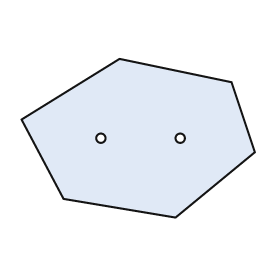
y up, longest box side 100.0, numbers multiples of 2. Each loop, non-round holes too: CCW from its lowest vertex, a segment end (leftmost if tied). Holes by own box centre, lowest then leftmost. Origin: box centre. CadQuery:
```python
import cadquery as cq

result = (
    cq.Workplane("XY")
    .moveTo(16.0, -34.0)
    .lineTo(50.0, -6.0)
    .lineTo(40.0, 24.0)
    .lineTo(-8.0, 34.0)
    .lineTo(-50.0, 8.0)
    .lineTo(-32.0, -26.0)
    .close()
    .moveTo(-16.0, 0.0)
    .circle(2.0)
    .moveTo(18.0, 0.0)
    .circle(2.0)
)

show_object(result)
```